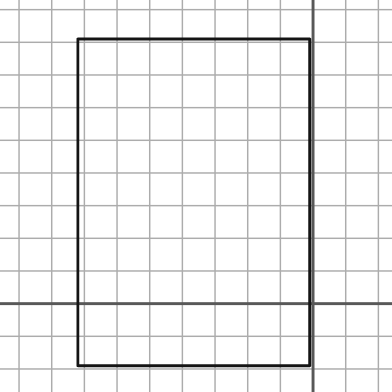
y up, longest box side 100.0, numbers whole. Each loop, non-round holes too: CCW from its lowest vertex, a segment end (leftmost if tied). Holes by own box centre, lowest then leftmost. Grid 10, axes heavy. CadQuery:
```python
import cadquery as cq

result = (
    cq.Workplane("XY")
    .moveTo(-72.0, -19.0)
    .lineTo(-1.0, -19.0)
    .lineTo(-1.0, 81.0)
    .lineTo(-72.0, 81.0)
    .close()
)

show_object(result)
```